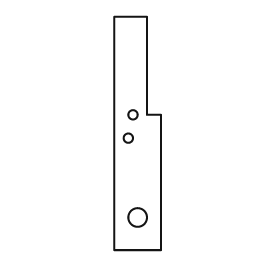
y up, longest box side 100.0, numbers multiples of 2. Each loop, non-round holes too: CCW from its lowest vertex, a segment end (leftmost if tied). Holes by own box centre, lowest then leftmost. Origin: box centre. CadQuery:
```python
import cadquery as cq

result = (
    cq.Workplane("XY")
    .moveTo(-10.0, -50.0)
    .lineTo(10.0, -50.0)
    .lineTo(10.0, 8.0)
    .lineTo(4.0, 8.0)
    .lineTo(4.0, 50.0)
    .lineTo(-10.0, 50.0)
    .close()
    .moveTo(0.0, -36.0)
    .circle(4.0)
    .moveTo(-4.0, -2.0)
    .circle(2.0)
    .moveTo(-2.0, 8.0)
    .circle(2.0)
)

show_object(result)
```